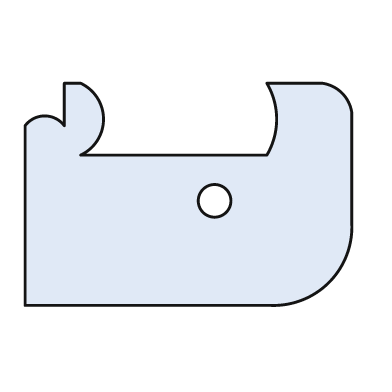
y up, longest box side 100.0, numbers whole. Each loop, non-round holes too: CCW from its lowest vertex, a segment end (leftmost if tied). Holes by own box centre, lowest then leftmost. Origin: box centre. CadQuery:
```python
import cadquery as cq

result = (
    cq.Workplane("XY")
    .moveTo(-50.0, -34.0)
    .lineTo(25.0, -34.0)
    .threePointArc((43.0, -27.0), (50.0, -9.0))
    .lineTo(50.0, 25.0)
    .threePointArc((47.0, 31.0), (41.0, 34.0))
    .lineTo(24.0, 34.0)
    .threePointArc((27.0, 23.0), (24.0, 12.0))
    .lineTo(-33.0, 12.0)
    .threePointArc((-26.0, 23.0), (-33.0, 34.0))
    .lineTo(-38.0, 34.0)
    .lineTo(-38.0, 21.0)
    .threePointArc((-44.0, 24.0), (-50.0, 21.0))
    .close()
    .moveTo(8.0, -2.0)
    .circle(5.0)
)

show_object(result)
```